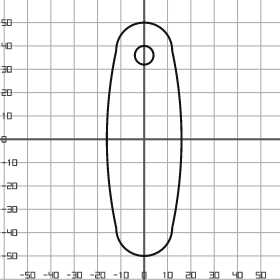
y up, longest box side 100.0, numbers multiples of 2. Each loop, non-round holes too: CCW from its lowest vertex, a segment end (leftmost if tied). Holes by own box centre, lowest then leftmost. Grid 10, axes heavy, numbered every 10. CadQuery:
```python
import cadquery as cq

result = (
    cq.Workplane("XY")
    .moveTo(-12.0, -38.0)
    .threePointArc((0.0, -50.0), (12.0, -38.0))
    .threePointArc((16.0, 0.0), (12.0, 38.0))
    .threePointArc((0.0, 50.0), (-12.0, 38.0))
    .threePointArc((-16.0, 0.0), (-12.0, -38.0))
    .close()
    .moveTo(0.0, 36.0)
    .circle(4.0)
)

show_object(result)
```